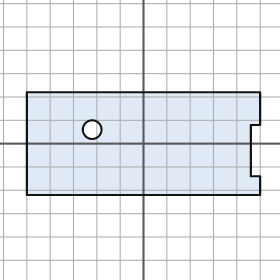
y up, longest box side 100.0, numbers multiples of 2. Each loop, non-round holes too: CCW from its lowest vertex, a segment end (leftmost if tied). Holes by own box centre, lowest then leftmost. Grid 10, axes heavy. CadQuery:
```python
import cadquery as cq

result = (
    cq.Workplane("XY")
    .moveTo(-50.0, -22.0)
    .lineTo(50.0, -22.0)
    .lineTo(50.0, -14.0)
    .lineTo(46.0, -14.0)
    .lineTo(46.0, 8.0)
    .lineTo(50.0, 8.0)
    .lineTo(50.0, 22.0)
    .lineTo(-50.0, 22.0)
    .close()
    .moveTo(-22.0, 6.0)
    .circle(4.0)
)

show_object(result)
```